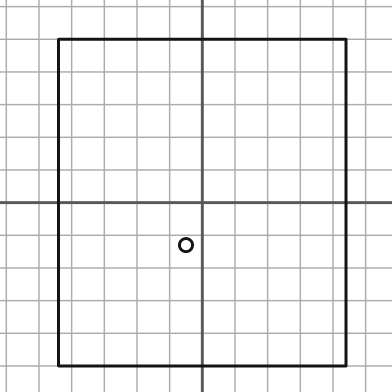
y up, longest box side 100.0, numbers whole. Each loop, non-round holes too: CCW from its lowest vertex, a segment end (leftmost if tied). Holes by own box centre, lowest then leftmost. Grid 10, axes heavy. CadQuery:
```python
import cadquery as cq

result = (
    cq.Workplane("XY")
    .moveTo(-44.0, -50.0)
    .lineTo(44.0, -50.0)
    .lineTo(44.0, 50.0)
    .lineTo(-44.0, 50.0)
    .close()
    .moveTo(-5.0, -13.0)
    .circle(2.0)
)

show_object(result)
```